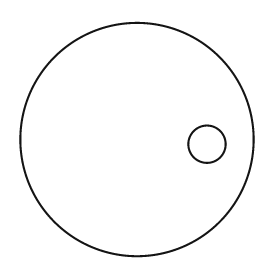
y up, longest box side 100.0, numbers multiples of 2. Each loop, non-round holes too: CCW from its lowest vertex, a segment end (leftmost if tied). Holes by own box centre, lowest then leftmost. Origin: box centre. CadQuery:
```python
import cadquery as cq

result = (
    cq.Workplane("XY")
    .moveTo(0.0, 0.0)
    .circle(50.0)
    .moveTo(30.0, -2.0)
    .circle(8.0)
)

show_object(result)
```